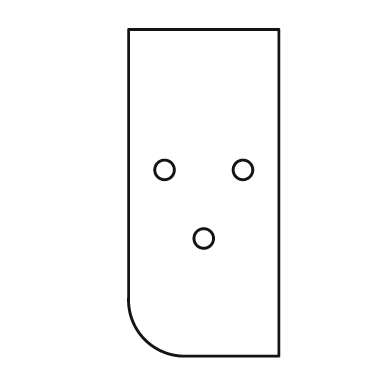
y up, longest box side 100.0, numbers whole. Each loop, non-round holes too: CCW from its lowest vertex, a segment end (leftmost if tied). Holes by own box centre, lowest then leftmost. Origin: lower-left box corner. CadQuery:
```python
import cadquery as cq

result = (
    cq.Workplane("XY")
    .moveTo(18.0, 0.0)
    .lineTo(46.0, 0.0)
    .lineTo(46.0, 100.0)
    .lineTo(0.0, 100.0)
    .lineTo(0.0, 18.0)
    .threePointArc((5.0, 5.0), (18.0, 0.0))
    .close()
    .moveTo(23.0, 36.0)
    .circle(3.0)
    .moveTo(11.0, 57.0)
    .circle(3.0)
    .moveTo(35.0, 57.0)
    .circle(3.0)
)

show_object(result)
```